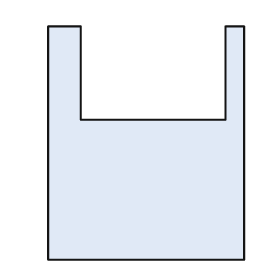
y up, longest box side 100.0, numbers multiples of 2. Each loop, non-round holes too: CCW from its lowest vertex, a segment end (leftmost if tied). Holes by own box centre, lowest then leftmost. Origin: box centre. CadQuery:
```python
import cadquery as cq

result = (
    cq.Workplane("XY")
    .moveTo(-42.0, -50.0)
    .lineTo(42.0, -50.0)
    .lineTo(42.0, 50.0)
    .lineTo(34.0, 50.0)
    .lineTo(34.0, 10.0)
    .lineTo(-28.0, 10.0)
    .lineTo(-28.0, 50.0)
    .lineTo(-42.0, 50.0)
    .close()
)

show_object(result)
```